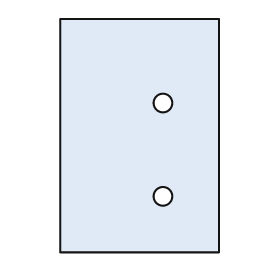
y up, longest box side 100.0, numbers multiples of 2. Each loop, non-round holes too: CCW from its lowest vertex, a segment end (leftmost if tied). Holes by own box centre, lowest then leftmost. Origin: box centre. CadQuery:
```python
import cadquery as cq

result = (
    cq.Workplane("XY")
    .moveTo(-34.0, -50.0)
    .lineTo(34.0, -50.0)
    .lineTo(34.0, 50.0)
    .lineTo(-34.0, 50.0)
    .close()
    .moveTo(10.0, -26.0)
    .circle(4.0)
    .moveTo(10.0, 14.0)
    .circle(4.0)
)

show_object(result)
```